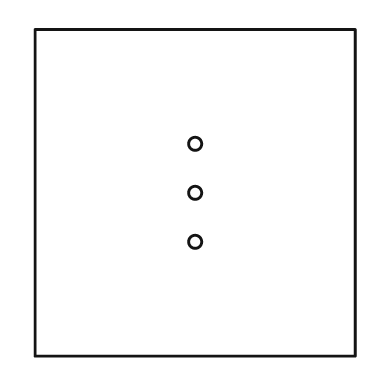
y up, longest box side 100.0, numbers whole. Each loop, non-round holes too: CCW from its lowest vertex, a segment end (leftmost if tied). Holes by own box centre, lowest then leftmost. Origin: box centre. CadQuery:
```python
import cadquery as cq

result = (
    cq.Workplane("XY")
    .moveTo(-49.0, -50.0)
    .lineTo(49.0, -50.0)
    .lineTo(49.0, 50.0)
    .lineTo(-49.0, 50.0)
    .close()
    .moveTo(0.0, -15.0)
    .circle(2.0)
    .moveTo(0.0, 0.0)
    .circle(2.0)
    .moveTo(0.0, 15.0)
    .circle(2.0)
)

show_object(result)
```